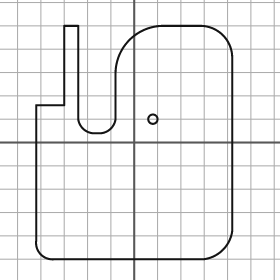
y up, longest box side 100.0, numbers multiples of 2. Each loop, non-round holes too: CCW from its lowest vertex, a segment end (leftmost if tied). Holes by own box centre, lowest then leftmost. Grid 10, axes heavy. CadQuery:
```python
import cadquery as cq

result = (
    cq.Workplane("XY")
    .moveTo(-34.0, -50.0)
    .lineTo(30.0, -50.0)
    .threePointArc((38.0, -46.0), (42.0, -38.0))
    .lineTo(42.0, 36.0)
    .threePointArc((38.0, 46.0), (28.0, 50.0))
    .lineTo(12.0, 50.0)
    .threePointArc((-2.0, 44.0), (-8.0, 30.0))
    .lineTo(-8.0, 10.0)
    .threePointArc((-10.0, 6.0), (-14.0, 4.0))
    .lineTo(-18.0, 4.0)
    .threePointArc((-22.0, 6.0), (-24.0, 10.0))
    .lineTo(-24.0, 50.0)
    .lineTo(-30.0, 50.0)
    .lineTo(-30.0, 16.0)
    .lineTo(-42.0, 16.0)
    .lineTo(-42.0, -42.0)
    .threePointArc((-40.0, -48.0), (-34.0, -50.0))
    .close()
    .moveTo(8.0, 10.0)
    .circle(2.0)
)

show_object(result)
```